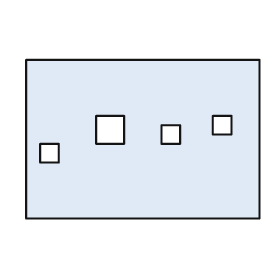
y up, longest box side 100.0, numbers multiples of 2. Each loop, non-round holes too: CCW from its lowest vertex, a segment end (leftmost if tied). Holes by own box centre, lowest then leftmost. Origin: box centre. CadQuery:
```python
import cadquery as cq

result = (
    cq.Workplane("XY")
    .moveTo(-50.0, -34.0)
    .lineTo(50.0, -34.0)
    .lineTo(50.0, 34.0)
    .lineTo(-50.0, 34.0)
    .close()
    .moveTo(-44.0, -10.0)
    .lineTo(-36.0, -10.0)
    .lineTo(-36.0, -2.0)
    .lineTo(-44.0, -2.0)
    .close()
    .moveTo(8.0, -2.0)
    .lineTo(16.0, -2.0)
    .lineTo(16.0, 6.0)
    .lineTo(8.0, 6.0)
    .close()
    .moveTo(-20.0, -2.0)
    .lineTo(-8.0, -2.0)
    .lineTo(-8.0, 10.0)
    .lineTo(-20.0, 10.0)
    .close()
    .moveTo(30.0, 2.0)
    .lineTo(38.0, 2.0)
    .lineTo(38.0, 10.0)
    .lineTo(30.0, 10.0)
    .close()
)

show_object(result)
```